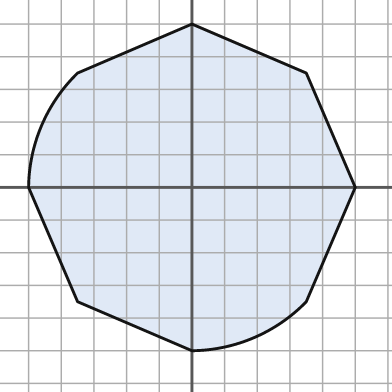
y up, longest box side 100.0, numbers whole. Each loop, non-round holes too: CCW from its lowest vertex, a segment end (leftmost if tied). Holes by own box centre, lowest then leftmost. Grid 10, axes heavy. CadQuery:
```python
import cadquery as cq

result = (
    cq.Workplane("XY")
    .moveTo(0.0, -50.0)
    .threePointArc((19.0, -46.0), (35.0, -35.0))
    .lineTo(50.0, 0.0)
    .lineTo(35.0, 35.0)
    .lineTo(0.0, 50.0)
    .lineTo(-35.0, 35.0)
    .threePointArc((-46.0, 19.0), (-50.0, 0.0))
    .lineTo(-35.0, -35.0)
    .close()
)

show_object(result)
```